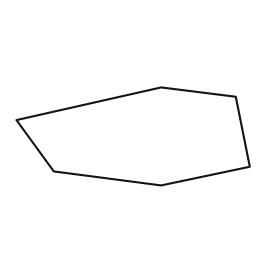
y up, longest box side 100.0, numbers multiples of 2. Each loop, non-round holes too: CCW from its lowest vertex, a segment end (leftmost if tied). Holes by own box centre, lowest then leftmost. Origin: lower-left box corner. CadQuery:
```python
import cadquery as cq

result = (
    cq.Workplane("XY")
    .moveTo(62.0, 0.0)
    .lineTo(100.0, 8.0)
    .lineTo(94.0, 38.0)
    .lineTo(62.0, 42.0)
    .lineTo(0.0, 28.0)
    .lineTo(16.0, 6.0)
    .close()
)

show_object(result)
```